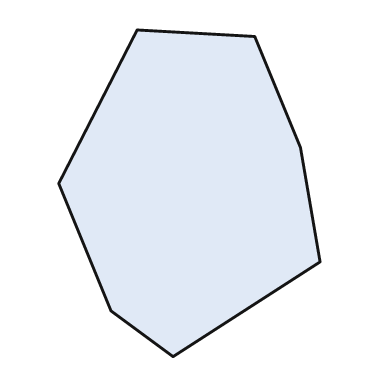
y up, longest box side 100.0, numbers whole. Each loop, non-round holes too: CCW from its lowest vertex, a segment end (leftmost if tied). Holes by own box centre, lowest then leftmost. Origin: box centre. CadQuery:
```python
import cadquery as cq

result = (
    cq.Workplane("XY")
    .moveTo(-5.0, -50.0)
    .lineTo(40.0, -21.0)
    .lineTo(34.0, 14.0)
    .lineTo(20.0, 48.0)
    .lineTo(-16.0, 50.0)
    .lineTo(-40.0, 3.0)
    .lineTo(-24.0, -36.0)
    .close()
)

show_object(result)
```